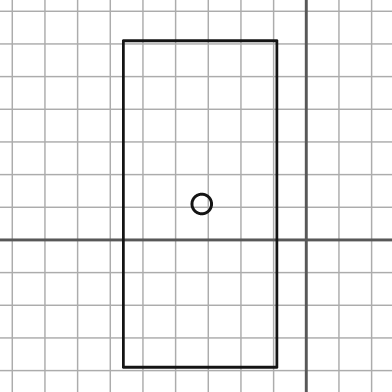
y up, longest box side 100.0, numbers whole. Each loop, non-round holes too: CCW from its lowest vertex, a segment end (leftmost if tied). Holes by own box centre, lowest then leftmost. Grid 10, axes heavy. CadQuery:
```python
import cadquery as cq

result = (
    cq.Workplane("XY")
    .moveTo(-56.0, -39.0)
    .lineTo(-9.0, -39.0)
    .lineTo(-9.0, 61.0)
    .lineTo(-56.0, 61.0)
    .close()
    .moveTo(-32.0, 11.0)
    .circle(3.0)
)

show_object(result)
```